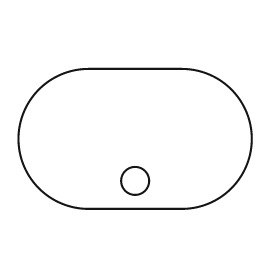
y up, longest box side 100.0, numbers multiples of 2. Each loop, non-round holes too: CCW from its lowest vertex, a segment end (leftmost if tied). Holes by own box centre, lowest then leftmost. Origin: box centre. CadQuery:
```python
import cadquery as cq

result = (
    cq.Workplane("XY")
    .moveTo(-20.0, -30.0)
    .lineTo(20.0, -30.0)
    .threePointArc((50.0, 0.0), (20.0, 30.0))
    .lineTo(-20.0, 30.0)
    .threePointArc((-50.0, 0.0), (-20.0, -30.0))
    .close()
    .moveTo(0.0, -18.0)
    .circle(6.0)
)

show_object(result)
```